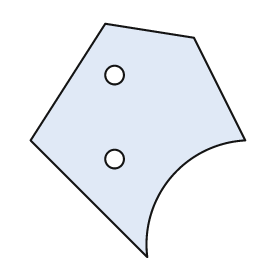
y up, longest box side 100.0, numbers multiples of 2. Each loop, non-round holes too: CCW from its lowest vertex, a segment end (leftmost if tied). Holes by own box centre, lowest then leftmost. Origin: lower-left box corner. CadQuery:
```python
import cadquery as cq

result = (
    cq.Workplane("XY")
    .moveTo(50.0, 0.0)
    .threePointArc((60.0, 34.0), (92.0, 50.0))
    .lineTo(70.0, 94.0)
    .lineTo(32.0, 100.0)
    .lineTo(0.0, 50.0)
    .close()
    .moveTo(36.0, 42.0)
    .circle(4.0)
    .moveTo(36.0, 78.0)
    .circle(4.0)
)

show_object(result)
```